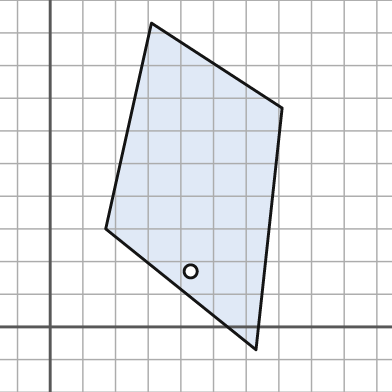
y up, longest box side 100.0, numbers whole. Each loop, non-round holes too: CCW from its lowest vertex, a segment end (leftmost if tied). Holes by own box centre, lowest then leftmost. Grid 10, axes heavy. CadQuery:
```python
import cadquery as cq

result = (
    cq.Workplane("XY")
    .moveTo(63.0, -7.0)
    .lineTo(71.0, 67.0)
    .lineTo(31.0, 93.0)
    .lineTo(17.0, 30.0)
    .close()
    .moveTo(43.0, 17.0)
    .circle(2.0)
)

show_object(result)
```